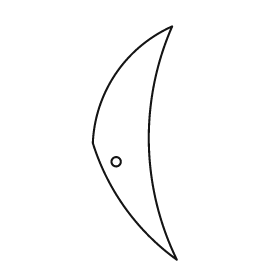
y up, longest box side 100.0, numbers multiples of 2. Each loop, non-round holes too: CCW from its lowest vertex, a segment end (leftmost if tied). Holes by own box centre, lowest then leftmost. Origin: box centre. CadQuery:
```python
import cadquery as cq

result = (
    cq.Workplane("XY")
    .moveTo(18.0, -50.0)
    .threePointArc((6.0, 0.0), (16.0, 50.0))
    .threePointArc((-8.0, 30.0), (-18.0, 0.0))
    .threePointArc((-4.0, -28.0), (18.0, -50.0))
    .close()
    .moveTo(-8.0, -8.0)
    .circle(2.0)
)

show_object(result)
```